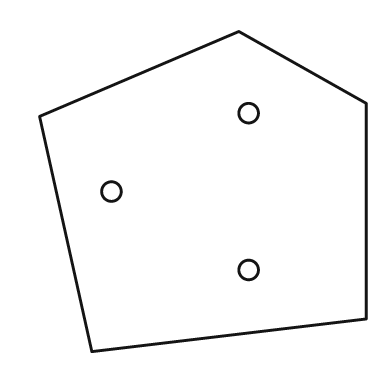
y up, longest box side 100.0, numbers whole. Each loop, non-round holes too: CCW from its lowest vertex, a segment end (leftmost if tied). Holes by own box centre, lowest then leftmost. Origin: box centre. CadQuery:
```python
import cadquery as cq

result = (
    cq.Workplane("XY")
    .moveTo(-34.0, -49.0)
    .lineTo(50.0, -39.0)
    .lineTo(50.0, 27.0)
    .lineTo(11.0, 49.0)
    .lineTo(-50.0, 23.0)
    .close()
    .moveTo(14.0, -24.0)
    .circle(3.0)
    .moveTo(-28.0, 0.0)
    .circle(3.0)
    .moveTo(14.0, 24.0)
    .circle(3.0)
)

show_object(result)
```